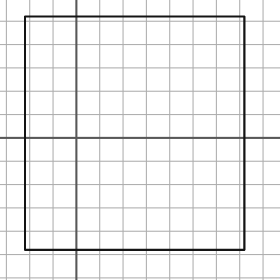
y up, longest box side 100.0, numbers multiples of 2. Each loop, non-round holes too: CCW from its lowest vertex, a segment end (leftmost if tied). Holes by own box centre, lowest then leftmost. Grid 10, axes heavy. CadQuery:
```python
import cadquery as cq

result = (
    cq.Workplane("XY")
    .moveTo(-22.0, -48.0)
    .lineTo(72.0, -48.0)
    .lineTo(72.0, 52.0)
    .lineTo(-22.0, 52.0)
    .close()
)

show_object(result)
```